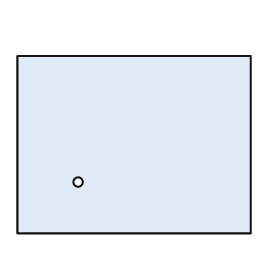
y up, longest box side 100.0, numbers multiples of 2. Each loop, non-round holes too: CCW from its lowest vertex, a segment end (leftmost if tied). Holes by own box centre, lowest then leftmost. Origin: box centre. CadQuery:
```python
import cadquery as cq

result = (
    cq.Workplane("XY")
    .moveTo(-50.0, -38.0)
    .lineTo(50.0, -38.0)
    .lineTo(50.0, 38.0)
    .lineTo(-50.0, 38.0)
    .close()
    .moveTo(-24.0, -16.0)
    .circle(2.0)
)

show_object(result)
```